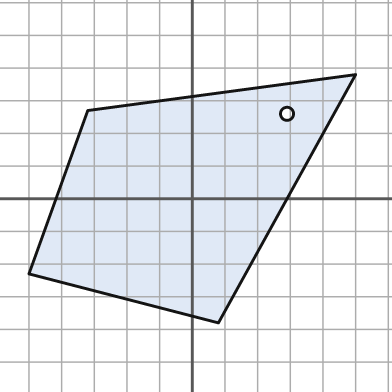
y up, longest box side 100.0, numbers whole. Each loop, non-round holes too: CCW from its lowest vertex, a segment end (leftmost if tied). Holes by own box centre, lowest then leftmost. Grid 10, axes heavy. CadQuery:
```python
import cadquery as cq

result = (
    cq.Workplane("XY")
    .moveTo(8.0, -38.0)
    .lineTo(50.0, 38.0)
    .lineTo(-32.0, 27.0)
    .lineTo(-50.0, -23.0)
    .close()
    .moveTo(29.0, 26.0)
    .circle(2.0)
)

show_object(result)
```